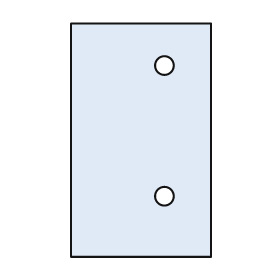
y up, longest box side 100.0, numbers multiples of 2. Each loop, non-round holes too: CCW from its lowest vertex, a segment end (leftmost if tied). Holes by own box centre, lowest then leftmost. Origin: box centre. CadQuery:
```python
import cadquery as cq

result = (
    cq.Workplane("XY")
    .moveTo(-30.0, -50.0)
    .lineTo(30.0, -50.0)
    .lineTo(30.0, 50.0)
    .lineTo(-30.0, 50.0)
    .close()
    .moveTo(10.0, -24.0)
    .circle(4.0)
    .moveTo(10.0, 32.0)
    .circle(4.0)
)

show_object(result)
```